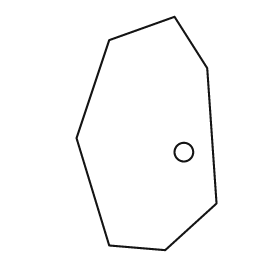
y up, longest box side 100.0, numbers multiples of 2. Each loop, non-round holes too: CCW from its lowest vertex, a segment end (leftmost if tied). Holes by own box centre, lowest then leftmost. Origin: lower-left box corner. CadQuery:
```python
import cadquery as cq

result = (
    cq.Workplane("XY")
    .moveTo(38.0, 0.0)
    .lineTo(60.0, 20.0)
    .lineTo(56.0, 78.0)
    .lineTo(42.0, 100.0)
    .lineTo(14.0, 90.0)
    .lineTo(0.0, 48.0)
    .lineTo(14.0, 2.0)
    .close()
    .moveTo(46.0, 42.0)
    .circle(4.0)
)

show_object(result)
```